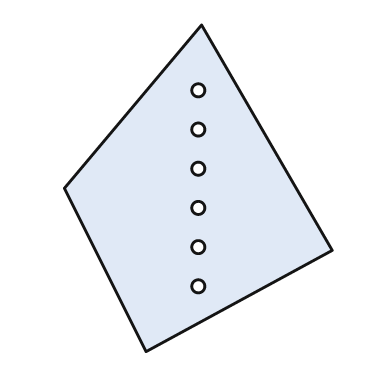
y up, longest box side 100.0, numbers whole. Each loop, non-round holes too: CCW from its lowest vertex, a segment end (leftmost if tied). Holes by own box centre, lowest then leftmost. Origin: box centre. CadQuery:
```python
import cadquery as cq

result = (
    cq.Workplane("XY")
    .moveTo(-16.0, -50.0)
    .lineTo(41.0, -19.0)
    .lineTo(1.0, 50.0)
    .lineTo(-41.0, 0.0)
    .close()
    .moveTo(0.0, -30.0)
    .circle(2.0)
    .moveTo(0.0, -18.0)
    .circle(2.0)
    .moveTo(0.0, -6.0)
    .circle(2.0)
    .moveTo(0.0, 6.0)
    .circle(2.0)
    .moveTo(0.0, 18.0)
    .circle(2.0)
    .moveTo(0.0, 30.0)
    .circle(2.0)
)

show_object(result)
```